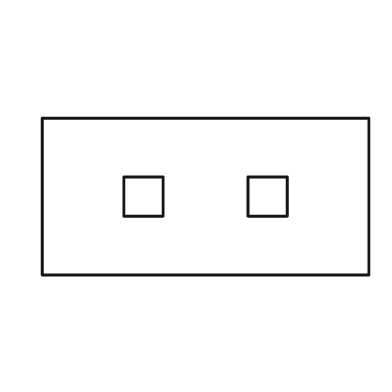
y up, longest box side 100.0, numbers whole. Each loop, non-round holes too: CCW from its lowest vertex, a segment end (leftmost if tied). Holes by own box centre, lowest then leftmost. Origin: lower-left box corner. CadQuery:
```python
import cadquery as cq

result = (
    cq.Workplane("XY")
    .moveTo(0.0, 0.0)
    .lineTo(100.0, 0.0)
    .lineTo(100.0, 48.0)
    .lineTo(0.0, 48.0)
    .close()
    .moveTo(25.0, 18.0)
    .lineTo(37.0, 18.0)
    .lineTo(37.0, 30.0)
    .lineTo(25.0, 30.0)
    .close()
    .moveTo(63.0, 18.0)
    .lineTo(75.0, 18.0)
    .lineTo(75.0, 30.0)
    .lineTo(63.0, 30.0)
    .close()
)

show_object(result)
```